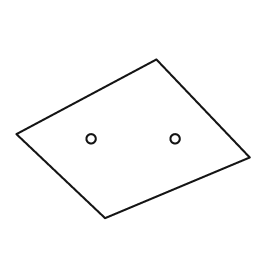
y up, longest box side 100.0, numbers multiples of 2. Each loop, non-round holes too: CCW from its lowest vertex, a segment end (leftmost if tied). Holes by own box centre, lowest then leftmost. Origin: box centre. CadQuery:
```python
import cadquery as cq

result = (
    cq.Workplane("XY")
    .moveTo(-12.0, -34.0)
    .lineTo(50.0, -8.0)
    .lineTo(10.0, 34.0)
    .lineTo(-50.0, 2.0)
    .close()
    .moveTo(-18.0, 0.0)
    .circle(2.0)
    .moveTo(18.0, 0.0)
    .circle(2.0)
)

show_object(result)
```